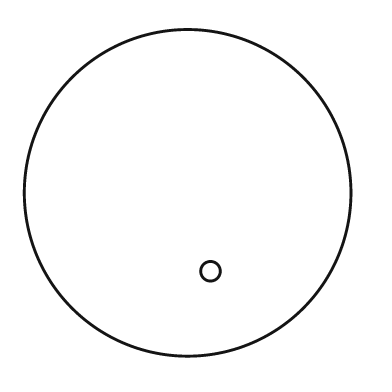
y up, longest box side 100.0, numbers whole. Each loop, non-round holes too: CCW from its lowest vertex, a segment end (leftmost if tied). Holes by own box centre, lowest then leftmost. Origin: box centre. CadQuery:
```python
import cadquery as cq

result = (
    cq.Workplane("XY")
    .moveTo(0.0, 0.0)
    .circle(50.0)
    .moveTo(7.0, -24.0)
    .circle(3.0)
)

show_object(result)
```